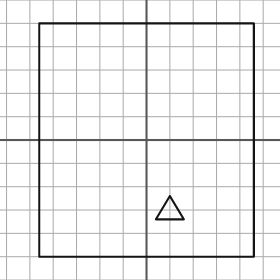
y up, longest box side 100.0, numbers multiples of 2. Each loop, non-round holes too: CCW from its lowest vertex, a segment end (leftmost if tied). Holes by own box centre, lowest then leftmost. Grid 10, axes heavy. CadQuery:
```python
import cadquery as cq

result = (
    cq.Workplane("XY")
    .moveTo(-46.0, -50.0)
    .lineTo(46.0, -50.0)
    .lineTo(46.0, 50.0)
    .lineTo(-46.0, 50.0)
    .close()
    .moveTo(4.0, -34.0)
    .lineTo(16.0, -34.0)
    .lineTo(10.0, -24.0)
    .close()
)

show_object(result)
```